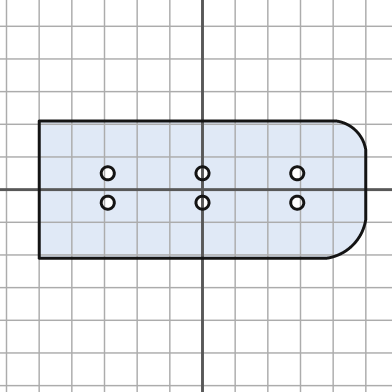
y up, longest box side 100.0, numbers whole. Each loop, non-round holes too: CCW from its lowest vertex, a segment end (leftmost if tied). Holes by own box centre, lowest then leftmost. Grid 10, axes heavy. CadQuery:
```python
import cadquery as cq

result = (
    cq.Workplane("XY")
    .moveTo(-50.0, -21.0)
    .lineTo(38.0, -21.0)
    .threePointArc((46.0, -17.0), (50.0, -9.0))
    .lineTo(50.0, 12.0)
    .threePointArc((47.0, 18.0), (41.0, 21.0))
    .lineTo(-50.0, 21.0)
    .close()
    .moveTo(-29.0, -4.0)
    .circle(2.0)
    .moveTo(0.0, -4.0)
    .circle(2.0)
    .moveTo(29.0, -4.0)
    .circle(2.0)
    .moveTo(-29.0, 5.0)
    .circle(2.0)
    .moveTo(0.0, 5.0)
    .circle(2.0)
    .moveTo(29.0, 5.0)
    .circle(2.0)
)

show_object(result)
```